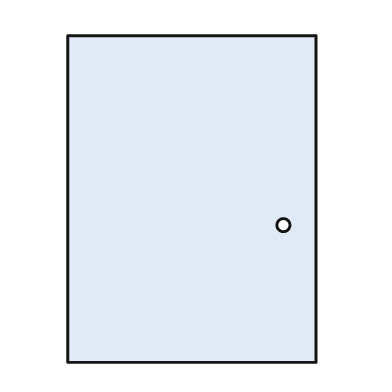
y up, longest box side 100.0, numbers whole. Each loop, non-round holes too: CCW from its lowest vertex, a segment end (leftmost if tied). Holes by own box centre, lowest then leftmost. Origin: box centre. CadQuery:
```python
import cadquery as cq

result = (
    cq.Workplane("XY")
    .moveTo(-38.0, -50.0)
    .lineTo(38.0, -50.0)
    .lineTo(38.0, 50.0)
    .lineTo(-38.0, 50.0)
    .close()
    .moveTo(28.0, -8.0)
    .circle(2.0)
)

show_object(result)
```